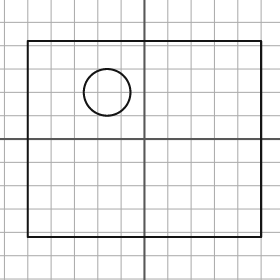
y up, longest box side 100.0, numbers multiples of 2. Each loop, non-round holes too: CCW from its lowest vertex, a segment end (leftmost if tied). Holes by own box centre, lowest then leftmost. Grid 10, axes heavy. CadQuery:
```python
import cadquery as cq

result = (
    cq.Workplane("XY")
    .moveTo(-50.0, -42.0)
    .lineTo(50.0, -42.0)
    .lineTo(50.0, 42.0)
    .lineTo(-50.0, 42.0)
    .close()
    .moveTo(-16.0, 20.0)
    .circle(10.0)
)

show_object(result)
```